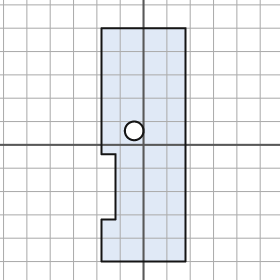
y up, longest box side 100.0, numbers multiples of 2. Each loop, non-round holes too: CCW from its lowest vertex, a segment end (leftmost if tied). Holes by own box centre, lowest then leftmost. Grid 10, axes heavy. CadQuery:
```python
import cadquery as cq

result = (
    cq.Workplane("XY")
    .moveTo(-18.0, -50.0)
    .lineTo(18.0, -50.0)
    .lineTo(18.0, 50.0)
    .lineTo(-18.0, 50.0)
    .lineTo(-18.0, -4.0)
    .lineTo(-12.0, -4.0)
    .lineTo(-12.0, -32.0)
    .lineTo(-18.0, -32.0)
    .close()
    .moveTo(-4.0, 6.0)
    .circle(4.0)
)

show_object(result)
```